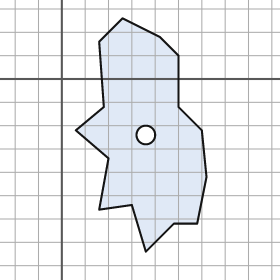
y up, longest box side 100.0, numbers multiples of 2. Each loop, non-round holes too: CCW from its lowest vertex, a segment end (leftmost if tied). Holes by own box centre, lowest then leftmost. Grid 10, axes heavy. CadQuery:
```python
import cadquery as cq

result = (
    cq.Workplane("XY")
    .moveTo(36.0, -74.0)
    .lineTo(48.0, -62.0)
    .lineTo(58.0, -62.0)
    .lineTo(62.0, -42.0)
    .lineTo(60.0, -22.0)
    .lineTo(50.0, -12.0)
    .lineTo(50.0, 10.0)
    .lineTo(42.0, 18.0)
    .lineTo(26.0, 26.0)
    .lineTo(16.0, 16.0)
    .lineTo(18.0, -12.0)
    .lineTo(6.0, -22.0)
    .lineTo(20.0, -34.0)
    .lineTo(16.0, -56.0)
    .lineTo(30.0, -54.0)
    .close()
    .moveTo(36.0, -24.0)
    .circle(4.0)
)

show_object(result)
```